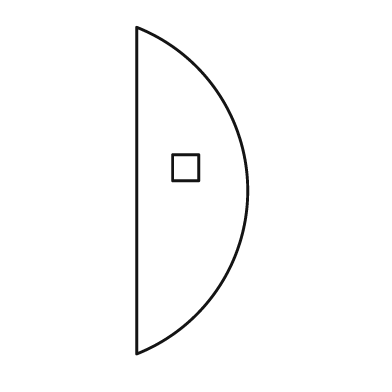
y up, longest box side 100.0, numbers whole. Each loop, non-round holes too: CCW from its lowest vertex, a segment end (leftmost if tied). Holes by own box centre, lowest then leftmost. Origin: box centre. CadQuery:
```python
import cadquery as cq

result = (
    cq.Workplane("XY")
    .moveTo(-17.0, -50.0)
    .threePointArc((17.0, 0.0), (-17.0, 50.0))
    .close()
    .moveTo(-6.0, 3.0)
    .lineTo(2.0, 3.0)
    .lineTo(2.0, 11.0)
    .lineTo(-6.0, 11.0)
    .close()
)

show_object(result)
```